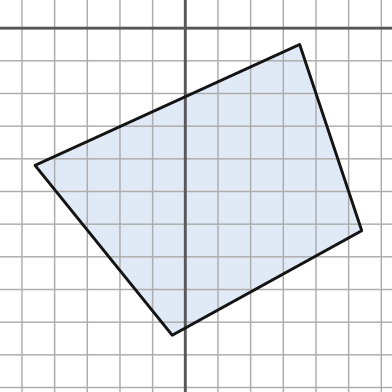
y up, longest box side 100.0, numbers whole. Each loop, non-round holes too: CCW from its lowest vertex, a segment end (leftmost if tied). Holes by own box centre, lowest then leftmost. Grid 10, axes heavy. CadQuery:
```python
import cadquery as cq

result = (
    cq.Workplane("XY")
    .moveTo(-4.0, -94.0)
    .lineTo(54.0, -62.0)
    .lineTo(35.0, -5.0)
    .lineTo(-46.0, -42.0)
    .close()
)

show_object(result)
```